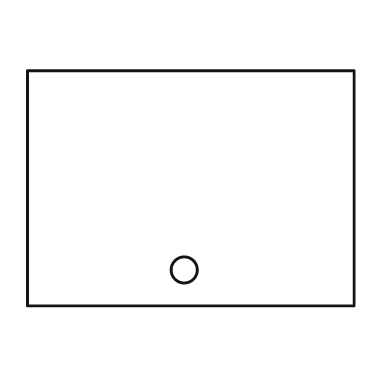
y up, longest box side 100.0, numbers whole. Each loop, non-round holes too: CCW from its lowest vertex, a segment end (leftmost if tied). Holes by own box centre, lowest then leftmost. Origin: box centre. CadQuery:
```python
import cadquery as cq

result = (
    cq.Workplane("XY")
    .moveTo(-50.0, -36.0)
    .lineTo(50.0, -36.0)
    .lineTo(50.0, 36.0)
    .lineTo(-50.0, 36.0)
    .close()
    .moveTo(-2.0, -25.0)
    .circle(4.0)
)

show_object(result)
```